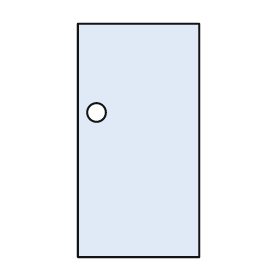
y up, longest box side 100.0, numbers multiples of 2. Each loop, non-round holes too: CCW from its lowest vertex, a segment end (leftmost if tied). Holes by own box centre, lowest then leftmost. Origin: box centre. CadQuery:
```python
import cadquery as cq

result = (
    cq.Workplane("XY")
    .moveTo(-26.0, -50.0)
    .lineTo(26.0, -50.0)
    .lineTo(26.0, 50.0)
    .lineTo(-26.0, 50.0)
    .close()
    .moveTo(-18.0, 12.0)
    .circle(4.0)
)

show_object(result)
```